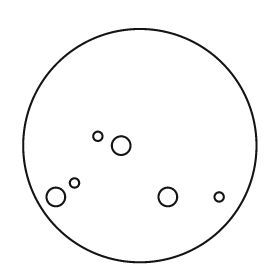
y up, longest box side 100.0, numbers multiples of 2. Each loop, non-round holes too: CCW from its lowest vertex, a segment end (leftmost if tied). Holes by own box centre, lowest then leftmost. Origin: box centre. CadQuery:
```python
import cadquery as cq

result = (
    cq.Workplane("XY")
    .moveTo(0.0, 0.0)
    .circle(50.0)
    .moveTo(-36.0, -22.0)
    .circle(4.0)
    .moveTo(12.0, -22.0)
    .circle(4.0)
    .moveTo(34.0, -22.0)
    .circle(2.0)
    .moveTo(-28.0, -16.0)
    .circle(2.0)
    .moveTo(-8.0, 0.0)
    .circle(4.0)
    .moveTo(-18.0, 4.0)
    .circle(2.0)
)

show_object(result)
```